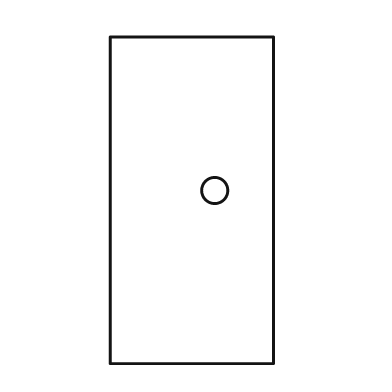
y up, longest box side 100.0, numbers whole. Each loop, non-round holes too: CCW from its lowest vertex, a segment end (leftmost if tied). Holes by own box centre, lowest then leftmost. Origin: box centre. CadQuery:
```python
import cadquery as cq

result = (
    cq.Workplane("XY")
    .moveTo(-25.0, -50.0)
    .lineTo(25.0, -50.0)
    .lineTo(25.0, 50.0)
    .lineTo(-25.0, 50.0)
    .close()
    .moveTo(7.0, 3.0)
    .circle(4.0)
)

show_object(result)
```